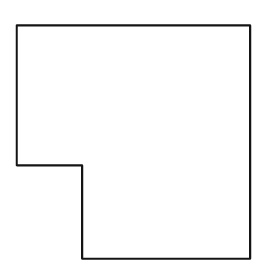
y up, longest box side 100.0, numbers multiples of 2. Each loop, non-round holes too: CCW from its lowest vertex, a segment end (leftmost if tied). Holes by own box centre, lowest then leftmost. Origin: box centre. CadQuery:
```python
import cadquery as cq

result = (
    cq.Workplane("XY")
    .moveTo(-22.0, -50.0)
    .lineTo(50.0, -50.0)
    .lineTo(50.0, 50.0)
    .lineTo(-50.0, 50.0)
    .lineTo(-50.0, -10.0)
    .lineTo(-22.0, -10.0)
    .close()
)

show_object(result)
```